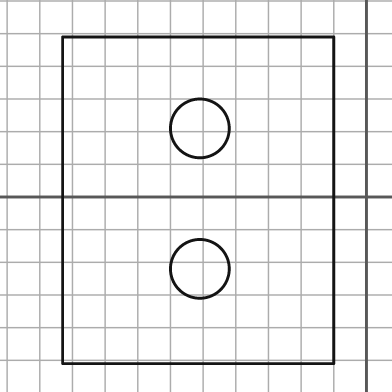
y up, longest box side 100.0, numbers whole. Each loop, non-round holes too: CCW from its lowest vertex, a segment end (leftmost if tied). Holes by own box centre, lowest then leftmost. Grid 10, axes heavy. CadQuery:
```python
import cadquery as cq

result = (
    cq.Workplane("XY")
    .moveTo(-93.0, -51.0)
    .lineTo(-10.0, -51.0)
    .lineTo(-10.0, 49.0)
    .lineTo(-93.0, 49.0)
    .close()
    .moveTo(-51.0, -22.0)
    .circle(9.0)
    .moveTo(-51.0, 21.0)
    .circle(9.0)
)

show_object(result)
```